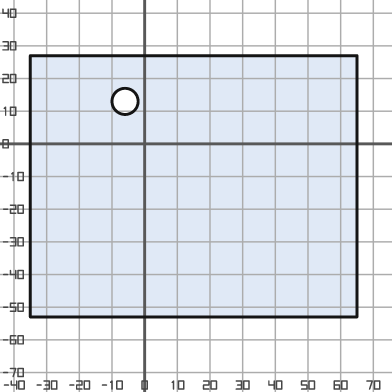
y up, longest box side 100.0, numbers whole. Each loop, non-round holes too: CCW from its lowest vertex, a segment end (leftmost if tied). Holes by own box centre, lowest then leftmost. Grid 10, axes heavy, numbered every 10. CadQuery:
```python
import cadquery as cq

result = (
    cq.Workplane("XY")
    .moveTo(-35.0, -53.0)
    .lineTo(65.0, -53.0)
    .lineTo(65.0, 27.0)
    .lineTo(-35.0, 27.0)
    .close()
    .moveTo(-6.0, 13.0)
    .circle(4.0)
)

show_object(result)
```